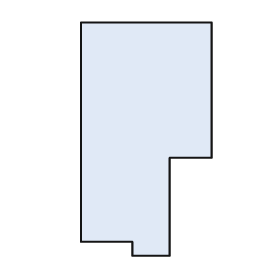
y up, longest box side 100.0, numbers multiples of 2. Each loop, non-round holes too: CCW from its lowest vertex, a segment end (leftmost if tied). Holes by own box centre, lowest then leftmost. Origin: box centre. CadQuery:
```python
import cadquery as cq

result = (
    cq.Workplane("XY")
    .moveTo(-6.0, -50.0)
    .lineTo(10.0, -50.0)
    .lineTo(10.0, -8.0)
    .lineTo(28.0, -8.0)
    .lineTo(28.0, 50.0)
    .lineTo(-28.0, 50.0)
    .lineTo(-28.0, -44.0)
    .lineTo(-6.0, -44.0)
    .close()
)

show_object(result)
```